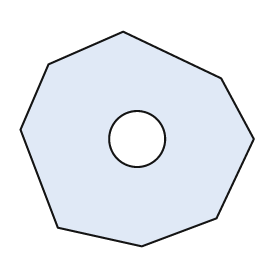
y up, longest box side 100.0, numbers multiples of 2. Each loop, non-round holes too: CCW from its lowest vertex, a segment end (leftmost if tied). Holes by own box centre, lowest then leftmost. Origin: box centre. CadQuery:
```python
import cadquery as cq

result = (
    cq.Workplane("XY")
    .moveTo(2.0, -46.0)
    .lineTo(34.0, -34.0)
    .lineTo(50.0, 0.0)
    .lineTo(36.0, 26.0)
    .lineTo(-6.0, 46.0)
    .lineTo(-38.0, 32.0)
    .lineTo(-50.0, 4.0)
    .lineTo(-34.0, -38.0)
    .close()
    .moveTo(0.0, 0.0)
    .circle(12.0)
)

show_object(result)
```